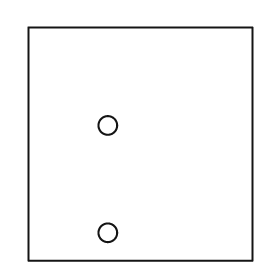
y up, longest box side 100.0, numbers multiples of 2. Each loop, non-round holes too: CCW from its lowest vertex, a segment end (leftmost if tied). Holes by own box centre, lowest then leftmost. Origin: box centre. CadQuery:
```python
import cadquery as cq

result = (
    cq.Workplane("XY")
    .moveTo(-48.0, -50.0)
    .lineTo(48.0, -50.0)
    .lineTo(48.0, 50.0)
    .lineTo(-48.0, 50.0)
    .close()
    .moveTo(-14.0, -38.0)
    .circle(4.0)
    .moveTo(-14.0, 8.0)
    .circle(4.0)
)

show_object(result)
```